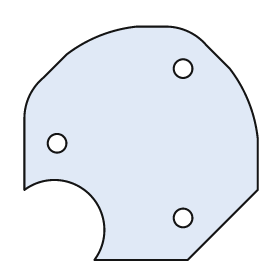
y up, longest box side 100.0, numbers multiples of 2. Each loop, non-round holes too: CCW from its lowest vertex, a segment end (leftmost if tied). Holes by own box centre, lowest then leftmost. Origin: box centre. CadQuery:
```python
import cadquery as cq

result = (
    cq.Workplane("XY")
    .moveTo(-20.0, -50.0)
    .lineTo(20.0, -50.0)
    .lineTo(50.0, -20.0)
    .lineTo(50.0, 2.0)
    .threePointArc((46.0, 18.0), (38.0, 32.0))
    .lineTo(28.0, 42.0)
    .threePointArc((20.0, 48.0), (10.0, 50.0))
    .lineTo(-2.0, 50.0)
    .threePointArc((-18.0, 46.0), (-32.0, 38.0))
    .lineTo(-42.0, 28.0)
    .threePointArc((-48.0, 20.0), (-50.0, 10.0))
    .lineTo(-50.0, -20.0)
    .threePointArc((-22.0, -22.0), (-20.0, -50.0))
    .close()
    .moveTo(18.0, -32.0)
    .circle(4.0)
    .moveTo(-36.0, 0.0)
    .circle(4.0)
    .moveTo(18.0, 32.0)
    .circle(4.0)
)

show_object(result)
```